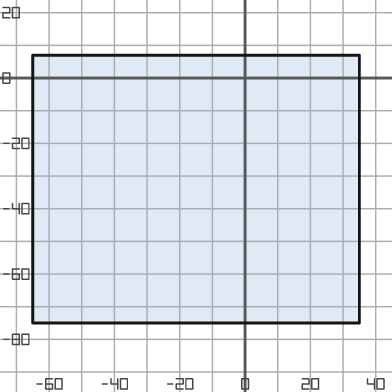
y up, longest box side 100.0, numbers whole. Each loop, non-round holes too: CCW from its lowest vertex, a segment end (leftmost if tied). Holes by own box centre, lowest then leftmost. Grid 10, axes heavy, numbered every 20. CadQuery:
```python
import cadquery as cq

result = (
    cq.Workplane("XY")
    .moveTo(-65.0, -75.0)
    .lineTo(35.0, -75.0)
    .lineTo(35.0, 7.0)
    .lineTo(-65.0, 7.0)
    .close()
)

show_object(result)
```